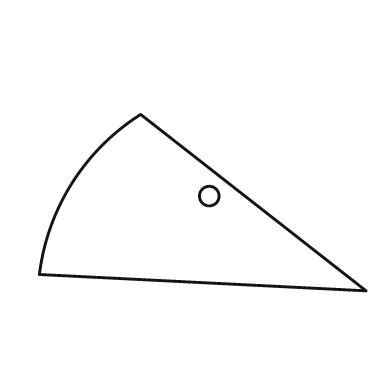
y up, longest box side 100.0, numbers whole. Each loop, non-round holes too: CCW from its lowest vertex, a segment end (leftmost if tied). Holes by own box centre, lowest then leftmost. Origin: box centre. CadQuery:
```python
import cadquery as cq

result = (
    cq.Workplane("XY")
    .moveTo(50.0, -27.0)
    .lineTo(-19.0, 27.0)
    .threePointArc((-40.0, 6.0), (-50.0, -22.0))
    .close()
    .moveTo(2.0, 2.0)
    .circle(3.0)
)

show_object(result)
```